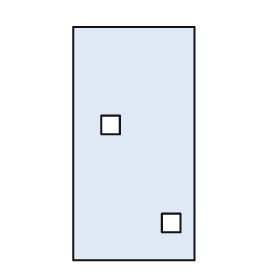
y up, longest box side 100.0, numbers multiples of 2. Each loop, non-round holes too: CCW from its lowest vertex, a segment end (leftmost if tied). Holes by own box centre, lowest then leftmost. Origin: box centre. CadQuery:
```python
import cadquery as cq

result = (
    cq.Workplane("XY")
    .moveTo(-26.0, -50.0)
    .lineTo(26.0, -50.0)
    .lineTo(26.0, 50.0)
    .lineTo(-26.0, 50.0)
    .close()
    .moveTo(12.0, -38.0)
    .lineTo(20.0, -38.0)
    .lineTo(20.0, -30.0)
    .lineTo(12.0, -30.0)
    .close()
    .moveTo(-14.0, 4.0)
    .lineTo(-6.0, 4.0)
    .lineTo(-6.0, 12.0)
    .lineTo(-14.0, 12.0)
    .close()
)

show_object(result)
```